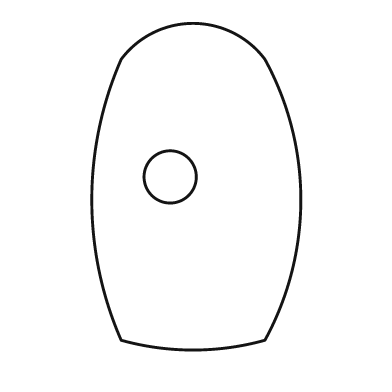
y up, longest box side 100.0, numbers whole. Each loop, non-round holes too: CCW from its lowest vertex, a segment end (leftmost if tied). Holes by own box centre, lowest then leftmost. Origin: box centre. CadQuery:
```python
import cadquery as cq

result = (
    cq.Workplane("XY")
    .moveTo(-23.0, -47.0)
    .threePointArc((-1.0, -50.0), (21.0, -47.0))
    .threePointArc((32.0, -4.0), (21.0, 39.0))
    .threePointArc((-1.0, 50.0), (-23.0, 39.0))
    .threePointArc((-32.0, -4.0), (-23.0, -47.0))
    .close()
    .moveTo(-8.0, 3.0)
    .circle(8.0)
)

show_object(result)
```